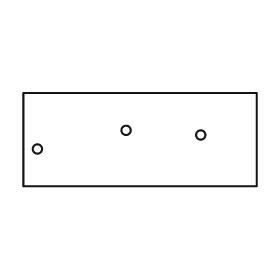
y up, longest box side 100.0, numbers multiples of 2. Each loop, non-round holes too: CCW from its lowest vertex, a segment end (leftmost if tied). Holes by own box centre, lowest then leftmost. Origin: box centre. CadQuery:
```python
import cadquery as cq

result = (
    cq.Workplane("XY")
    .moveTo(-50.0, -20.0)
    .lineTo(50.0, -20.0)
    .lineTo(50.0, 20.0)
    .lineTo(-50.0, 20.0)
    .close()
    .moveTo(-44.0, -4.0)
    .circle(2.0)
    .moveTo(26.0, 2.0)
    .circle(2.0)
    .moveTo(-6.0, 4.0)
    .circle(2.0)
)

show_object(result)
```